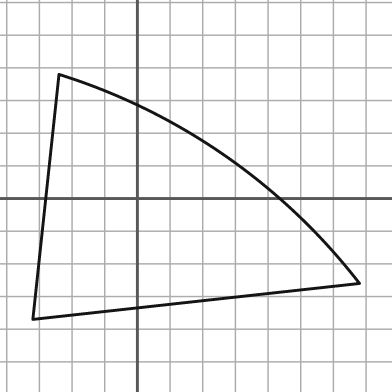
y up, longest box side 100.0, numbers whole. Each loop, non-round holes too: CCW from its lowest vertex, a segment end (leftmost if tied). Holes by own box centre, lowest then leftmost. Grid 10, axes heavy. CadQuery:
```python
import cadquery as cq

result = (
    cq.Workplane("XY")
    .moveTo(-32.0, -37.0)
    .lineTo(68.0, -26.0)
    .threePointArc((27.0, 13.0), (-24.0, 38.0))
    .close()
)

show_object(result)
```